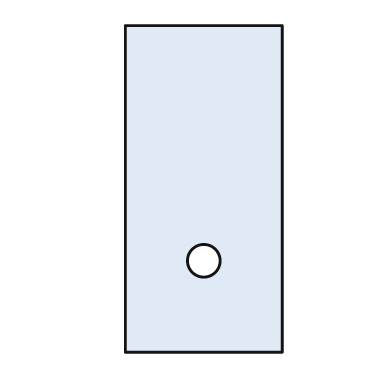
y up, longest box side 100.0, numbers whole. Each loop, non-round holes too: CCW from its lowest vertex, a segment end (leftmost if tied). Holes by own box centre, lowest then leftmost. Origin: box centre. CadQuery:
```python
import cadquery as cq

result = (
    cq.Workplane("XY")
    .moveTo(-24.0, -50.0)
    .lineTo(24.0, -50.0)
    .lineTo(24.0, 50.0)
    .lineTo(-24.0, 50.0)
    .close()
    .moveTo(0.0, -22.0)
    .circle(5.0)
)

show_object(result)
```